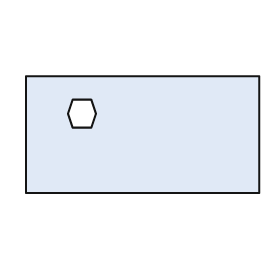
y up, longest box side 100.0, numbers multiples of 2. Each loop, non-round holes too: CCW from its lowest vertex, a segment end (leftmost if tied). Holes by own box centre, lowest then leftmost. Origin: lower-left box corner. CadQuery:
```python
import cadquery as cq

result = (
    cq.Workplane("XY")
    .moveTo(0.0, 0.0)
    .lineTo(100.0, 0.0)
    .lineTo(100.0, 50.0)
    .lineTo(0.0, 50.0)
    .close()
    .moveTo(20.0, 28.0)
    .lineTo(28.0, 28.0)
    .lineTo(30.0, 34.0)
    .lineTo(28.0, 40.0)
    .lineTo(20.0, 40.0)
    .lineTo(18.0, 34.0)
    .close()
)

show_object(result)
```